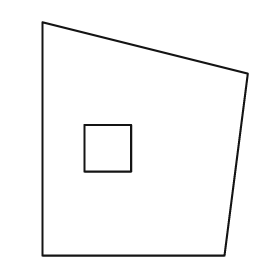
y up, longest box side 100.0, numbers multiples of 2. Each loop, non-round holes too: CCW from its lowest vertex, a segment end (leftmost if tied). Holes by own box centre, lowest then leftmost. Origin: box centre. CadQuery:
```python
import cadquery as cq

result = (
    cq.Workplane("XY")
    .moveTo(-44.0, -50.0)
    .lineTo(34.0, -50.0)
    .lineTo(44.0, 28.0)
    .lineTo(-44.0, 50.0)
    .close()
    .moveTo(-26.0, -14.0)
    .lineTo(-6.0, -14.0)
    .lineTo(-6.0, 6.0)
    .lineTo(-26.0, 6.0)
    .close()
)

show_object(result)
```